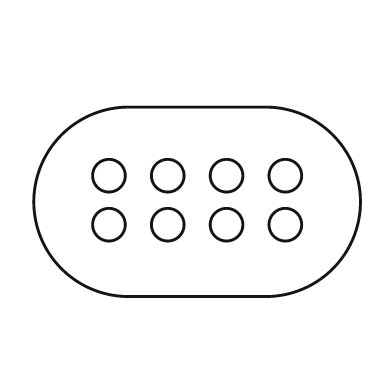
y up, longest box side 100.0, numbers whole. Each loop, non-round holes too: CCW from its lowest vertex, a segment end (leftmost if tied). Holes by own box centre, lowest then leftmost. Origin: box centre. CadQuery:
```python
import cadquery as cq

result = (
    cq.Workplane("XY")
    .moveTo(-21.0, -29.0)
    .lineTo(21.0, -29.0)
    .threePointArc((50.0, 0.0), (21.0, 29.0))
    .lineTo(-21.0, 29.0)
    .threePointArc((-50.0, 0.0), (-21.0, -29.0))
    .close()
    .moveTo(-27.0, -7.0)
    .circle(5.0)
    .moveTo(-9.0, -7.0)
    .circle(5.0)
    .moveTo(9.0, -7.0)
    .circle(5.0)
    .moveTo(27.0, -7.0)
    .circle(5.0)
    .moveTo(-27.0, 8.0)
    .circle(5.0)
    .moveTo(-9.0, 8.0)
    .circle(5.0)
    .moveTo(9.0, 8.0)
    .circle(5.0)
    .moveTo(27.0, 8.0)
    .circle(5.0)
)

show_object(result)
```